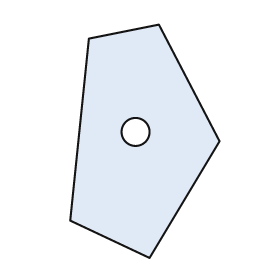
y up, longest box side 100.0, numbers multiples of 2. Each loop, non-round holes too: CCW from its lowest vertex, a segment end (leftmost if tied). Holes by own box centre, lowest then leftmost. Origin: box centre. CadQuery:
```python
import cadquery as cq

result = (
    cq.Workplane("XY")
    .moveTo(2.0, -50.0)
    .lineTo(32.0, 0.0)
    .lineTo(6.0, 50.0)
    .lineTo(-24.0, 44.0)
    .lineTo(-32.0, -34.0)
    .close()
    .moveTo(-4.0, 4.0)
    .circle(6.0)
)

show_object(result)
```